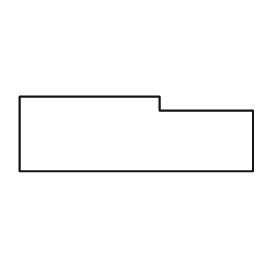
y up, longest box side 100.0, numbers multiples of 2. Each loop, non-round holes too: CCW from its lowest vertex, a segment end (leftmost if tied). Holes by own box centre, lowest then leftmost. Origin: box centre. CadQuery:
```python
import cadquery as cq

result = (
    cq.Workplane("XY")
    .moveTo(-50.0, -16.0)
    .lineTo(50.0, -16.0)
    .lineTo(50.0, 10.0)
    .lineTo(10.0, 10.0)
    .lineTo(10.0, 16.0)
    .lineTo(-50.0, 16.0)
    .close()
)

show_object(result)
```